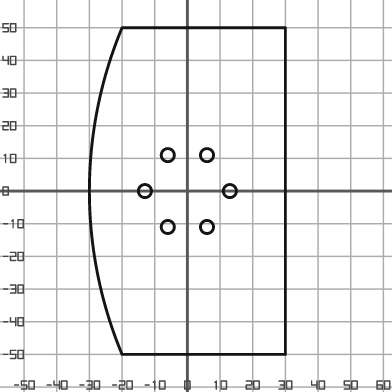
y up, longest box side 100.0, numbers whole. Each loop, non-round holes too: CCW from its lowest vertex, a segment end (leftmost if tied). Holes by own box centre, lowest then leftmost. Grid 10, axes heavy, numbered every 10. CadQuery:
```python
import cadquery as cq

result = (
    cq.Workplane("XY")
    .moveTo(-20.0, -50.0)
    .lineTo(30.0, -50.0)
    .lineTo(30.0, 50.0)
    .lineTo(-20.0, 50.0)
    .threePointArc((-30.0, 0.0), (-20.0, -50.0))
    .close()
    .moveTo(-6.0, -11.0)
    .circle(2.0)
    .moveTo(6.0, -11.0)
    .circle(2.0)
    .moveTo(-13.0, 0.0)
    .circle(2.0)
    .moveTo(13.0, 0.0)
    .circle(2.0)
    .moveTo(-6.0, 11.0)
    .circle(2.0)
    .moveTo(6.0, 11.0)
    .circle(2.0)
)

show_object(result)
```